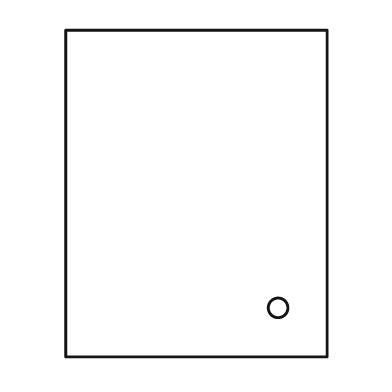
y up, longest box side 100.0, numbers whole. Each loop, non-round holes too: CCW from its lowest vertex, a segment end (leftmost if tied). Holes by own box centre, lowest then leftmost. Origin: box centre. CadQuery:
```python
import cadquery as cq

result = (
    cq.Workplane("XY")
    .moveTo(-40.0, -50.0)
    .lineTo(40.0, -50.0)
    .lineTo(40.0, 50.0)
    .lineTo(-40.0, 50.0)
    .close()
    .moveTo(25.0, -35.0)
    .circle(3.0)
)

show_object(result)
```